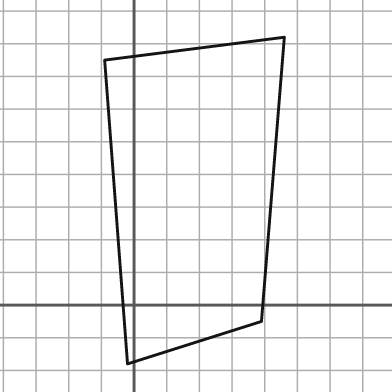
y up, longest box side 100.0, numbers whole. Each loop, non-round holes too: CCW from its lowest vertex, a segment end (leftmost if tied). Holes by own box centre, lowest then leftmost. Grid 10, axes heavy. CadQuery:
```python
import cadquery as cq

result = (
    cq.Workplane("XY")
    .moveTo(-2.0, -18.0)
    .lineTo(39.0, -5.0)
    .lineTo(46.0, 82.0)
    .lineTo(-9.0, 75.0)
    .close()
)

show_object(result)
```